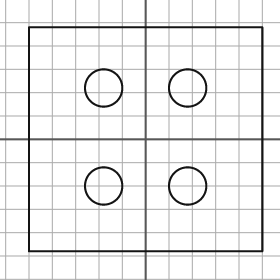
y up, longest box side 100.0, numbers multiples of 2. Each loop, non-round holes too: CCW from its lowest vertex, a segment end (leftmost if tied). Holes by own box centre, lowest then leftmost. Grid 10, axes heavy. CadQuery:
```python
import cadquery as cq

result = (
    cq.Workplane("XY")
    .moveTo(-50.0, -48.0)
    .lineTo(50.0, -48.0)
    .lineTo(50.0, 48.0)
    .lineTo(-50.0, 48.0)
    .close()
    .moveTo(-18.0, -20.0)
    .circle(8.0)
    .moveTo(18.0, -20.0)
    .circle(8.0)
    .moveTo(-18.0, 22.0)
    .circle(8.0)
    .moveTo(18.0, 22.0)
    .circle(8.0)
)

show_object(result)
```